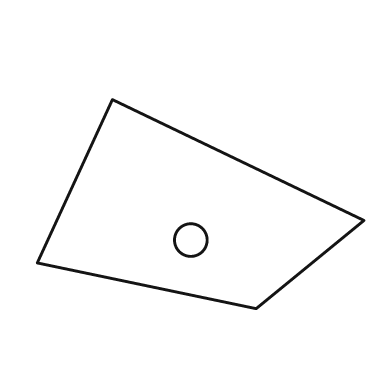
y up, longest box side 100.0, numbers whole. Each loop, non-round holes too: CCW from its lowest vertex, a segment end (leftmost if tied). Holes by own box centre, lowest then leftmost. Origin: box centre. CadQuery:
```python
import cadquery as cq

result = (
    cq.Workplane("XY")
    .moveTo(17.0, -32.0)
    .lineTo(50.0, -5.0)
    .lineTo(-27.0, 32.0)
    .lineTo(-50.0, -18.0)
    .close()
    .moveTo(-3.0, -11.0)
    .circle(5.0)
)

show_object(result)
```